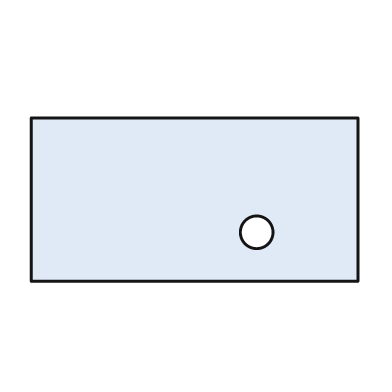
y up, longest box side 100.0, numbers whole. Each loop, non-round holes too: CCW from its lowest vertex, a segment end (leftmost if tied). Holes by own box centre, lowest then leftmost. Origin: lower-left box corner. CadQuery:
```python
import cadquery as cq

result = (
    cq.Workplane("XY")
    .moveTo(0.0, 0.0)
    .lineTo(100.0, 0.0)
    .lineTo(100.0, 50.0)
    .lineTo(0.0, 50.0)
    .close()
    .moveTo(69.0, 15.0)
    .circle(5.0)
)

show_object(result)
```